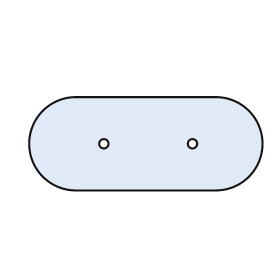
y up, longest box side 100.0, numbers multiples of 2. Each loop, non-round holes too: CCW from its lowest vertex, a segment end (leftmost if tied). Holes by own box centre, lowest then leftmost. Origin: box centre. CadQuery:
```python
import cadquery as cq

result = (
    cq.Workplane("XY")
    .moveTo(-30.0, -20.0)
    .lineTo(30.0, -20.0)
    .threePointArc((50.0, 0.0), (30.0, 20.0))
    .lineTo(-30.0, 20.0)
    .threePointArc((-50.0, 0.0), (-30.0, -20.0))
    .close()
    .moveTo(-18.0, 0.0)
    .circle(2.0)
    .moveTo(20.0, 0.0)
    .circle(2.0)
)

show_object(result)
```